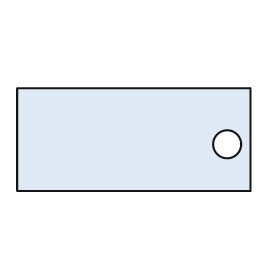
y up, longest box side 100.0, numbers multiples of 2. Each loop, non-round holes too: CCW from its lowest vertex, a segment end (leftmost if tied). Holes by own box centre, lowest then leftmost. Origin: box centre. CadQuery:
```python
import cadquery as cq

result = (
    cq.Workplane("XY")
    .moveTo(-50.0, -22.0)
    .lineTo(50.0, -22.0)
    .lineTo(50.0, 22.0)
    .lineTo(-50.0, 22.0)
    .close()
    .moveTo(40.0, -2.0)
    .circle(6.0)
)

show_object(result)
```